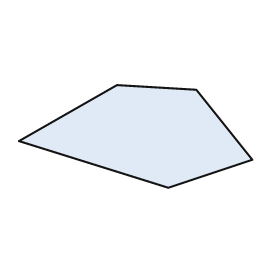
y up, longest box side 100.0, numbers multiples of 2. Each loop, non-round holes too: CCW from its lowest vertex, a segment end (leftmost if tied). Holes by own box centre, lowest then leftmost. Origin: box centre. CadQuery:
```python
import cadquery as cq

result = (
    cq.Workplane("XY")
    .moveTo(14.0, -22.0)
    .lineTo(50.0, -10.0)
    .lineTo(26.0, 20.0)
    .lineTo(-8.0, 22.0)
    .lineTo(-50.0, -2.0)
    .close()
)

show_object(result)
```